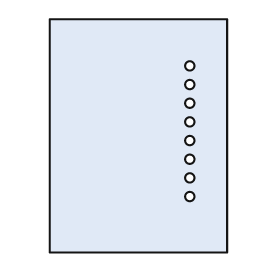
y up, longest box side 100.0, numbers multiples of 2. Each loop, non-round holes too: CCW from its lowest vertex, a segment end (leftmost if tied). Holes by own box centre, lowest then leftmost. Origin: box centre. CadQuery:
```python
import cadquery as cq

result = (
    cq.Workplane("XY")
    .moveTo(-38.0, -50.0)
    .lineTo(38.0, -50.0)
    .lineTo(38.0, 50.0)
    .lineTo(-38.0, 50.0)
    .close()
    .moveTo(22.0, -26.0)
    .circle(2.0)
    .moveTo(22.0, -18.0)
    .circle(2.0)
    .moveTo(22.0, -10.0)
    .circle(2.0)
    .moveTo(22.0, -2.0)
    .circle(2.0)
    .moveTo(22.0, 6.0)
    .circle(2.0)
    .moveTo(22.0, 14.0)
    .circle(2.0)
    .moveTo(22.0, 22.0)
    .circle(2.0)
    .moveTo(22.0, 30.0)
    .circle(2.0)
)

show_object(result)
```